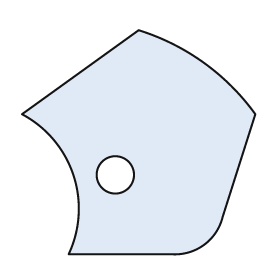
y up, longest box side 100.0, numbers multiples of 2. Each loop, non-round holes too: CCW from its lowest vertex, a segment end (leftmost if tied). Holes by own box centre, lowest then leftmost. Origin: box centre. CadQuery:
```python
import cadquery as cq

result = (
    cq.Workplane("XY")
    .moveTo(-30.0, -48.0)
    .lineTo(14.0, -48.0)
    .threePointArc((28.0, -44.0), (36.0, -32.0))
    .lineTo(50.0, 12.0)
    .threePointArc((28.0, 34.0), (0.0, 48.0))
    .lineTo(-50.0, 12.0)
    .threePointArc((-28.0, -14.0), (-30.0, -48.0))
    .close()
    .moveTo(-10.0, -14.0)
    .circle(8.0)
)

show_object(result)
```